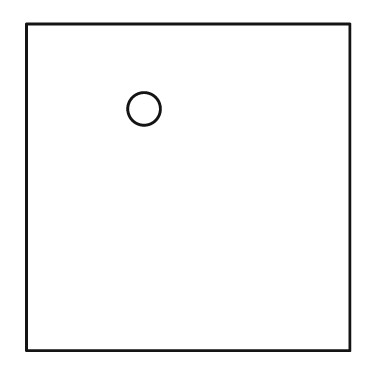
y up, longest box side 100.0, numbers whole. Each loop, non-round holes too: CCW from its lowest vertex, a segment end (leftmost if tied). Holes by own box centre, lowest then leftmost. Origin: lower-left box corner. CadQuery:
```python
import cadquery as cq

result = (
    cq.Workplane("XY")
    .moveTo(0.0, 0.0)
    .lineTo(99.0, 0.0)
    .lineTo(99.0, 100.0)
    .lineTo(0.0, 100.0)
    .close()
    .moveTo(36.0, 74.0)
    .circle(5.0)
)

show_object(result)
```